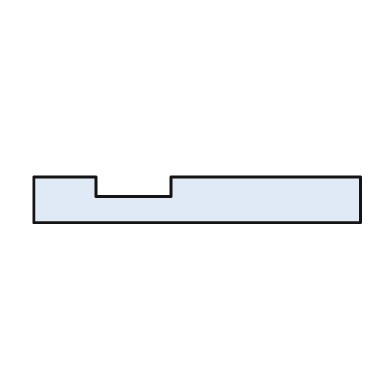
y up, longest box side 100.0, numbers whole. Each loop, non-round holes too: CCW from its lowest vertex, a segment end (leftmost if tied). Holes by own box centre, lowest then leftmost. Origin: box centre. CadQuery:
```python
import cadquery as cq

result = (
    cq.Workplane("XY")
    .moveTo(-50.0, -7.0)
    .lineTo(50.0, -7.0)
    .lineTo(50.0, 7.0)
    .lineTo(-8.0, 7.0)
    .lineTo(-8.0, 1.0)
    .lineTo(-31.0, 1.0)
    .lineTo(-31.0, 7.0)
    .lineTo(-50.0, 7.0)
    .close()
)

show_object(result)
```